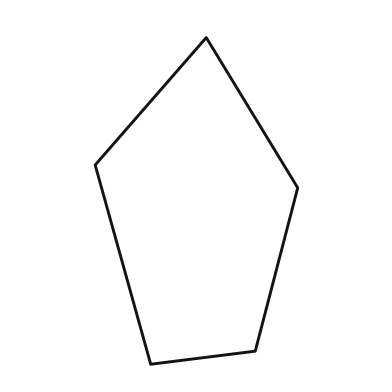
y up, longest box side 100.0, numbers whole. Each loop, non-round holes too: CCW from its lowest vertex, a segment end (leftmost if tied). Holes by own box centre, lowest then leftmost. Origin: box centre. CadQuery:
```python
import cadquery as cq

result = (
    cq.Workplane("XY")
    .moveTo(-14.0, -50.0)
    .lineTo(18.0, -46.0)
    .lineTo(31.0, 4.0)
    .lineTo(3.0, 50.0)
    .lineTo(-31.0, 11.0)
    .close()
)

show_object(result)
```